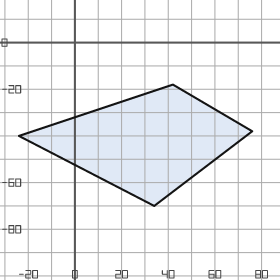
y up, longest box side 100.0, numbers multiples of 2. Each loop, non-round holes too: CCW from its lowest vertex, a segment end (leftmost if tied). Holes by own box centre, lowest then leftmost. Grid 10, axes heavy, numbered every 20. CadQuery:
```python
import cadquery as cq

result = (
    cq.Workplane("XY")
    .moveTo(34.0, -70.0)
    .lineTo(76.0, -38.0)
    .lineTo(42.0, -18.0)
    .lineTo(-24.0, -40.0)
    .close()
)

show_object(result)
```